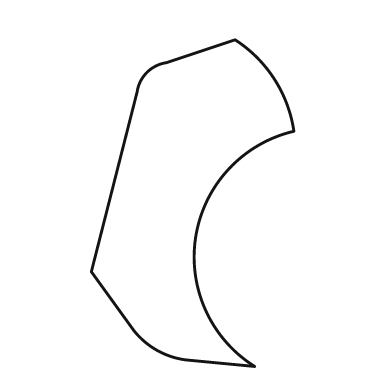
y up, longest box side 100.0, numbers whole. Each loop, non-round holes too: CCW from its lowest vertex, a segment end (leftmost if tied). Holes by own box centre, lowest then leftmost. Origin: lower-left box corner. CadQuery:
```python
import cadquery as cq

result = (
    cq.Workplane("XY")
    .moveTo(50.0, 0.0)
    .threePointArc((32.0, 40.0), (62.0, 72.0))
    .threePointArc((56.0, 88.0), (44.0, 100.0))
    .lineTo(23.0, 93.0)
    .threePointArc((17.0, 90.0), (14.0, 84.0))
    .lineTo(0.0, 29.0)
    .lineTo(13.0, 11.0)
    .threePointArc((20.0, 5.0), (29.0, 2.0))
    .close()
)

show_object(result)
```